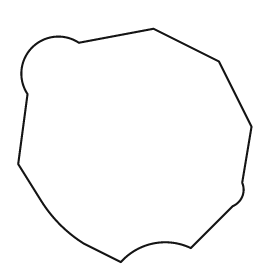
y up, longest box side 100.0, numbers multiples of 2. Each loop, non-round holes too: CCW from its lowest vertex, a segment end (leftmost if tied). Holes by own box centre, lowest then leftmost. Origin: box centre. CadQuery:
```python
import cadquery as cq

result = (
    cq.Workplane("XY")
    .moveTo(-6.0, -50.0)
    .threePointArc((8.0, -42.0), (24.0, -44.0))
    .lineTo(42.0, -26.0)
    .threePointArc((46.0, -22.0), (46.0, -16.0))
    .lineTo(50.0, 8.0)
    .lineTo(36.0, 36.0)
    .lineTo(8.0, 50.0)
    .lineTo(-24.0, 44.0)
    .threePointArc((-44.0, 42.0), (-46.0, 22.0))
    .lineTo(-50.0, -8.0)
    .lineTo(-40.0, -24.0)
    .threePointArc((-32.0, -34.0), (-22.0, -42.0))
    .close()
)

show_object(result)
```